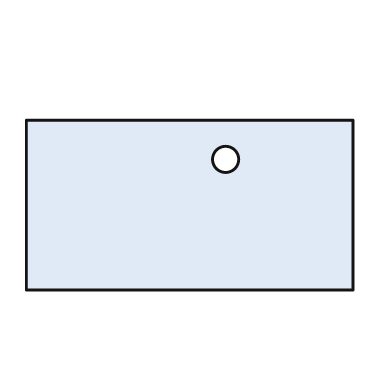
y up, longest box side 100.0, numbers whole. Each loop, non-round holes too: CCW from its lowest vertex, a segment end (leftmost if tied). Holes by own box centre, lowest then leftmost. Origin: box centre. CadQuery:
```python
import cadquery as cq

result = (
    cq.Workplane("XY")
    .moveTo(-50.0, -26.0)
    .lineTo(50.0, -26.0)
    .lineTo(50.0, 26.0)
    .lineTo(-50.0, 26.0)
    .close()
    .moveTo(11.0, 14.0)
    .circle(4.0)
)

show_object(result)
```